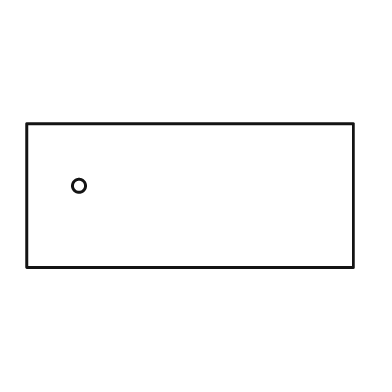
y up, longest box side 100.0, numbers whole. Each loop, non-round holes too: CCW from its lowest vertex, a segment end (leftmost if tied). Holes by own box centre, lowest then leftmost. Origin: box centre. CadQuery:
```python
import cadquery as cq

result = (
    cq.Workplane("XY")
    .moveTo(-50.0, -22.0)
    .lineTo(50.0, -22.0)
    .lineTo(50.0, 22.0)
    .lineTo(-50.0, 22.0)
    .close()
    .moveTo(-34.0, 3.0)
    .circle(2.0)
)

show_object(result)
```